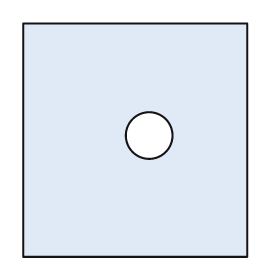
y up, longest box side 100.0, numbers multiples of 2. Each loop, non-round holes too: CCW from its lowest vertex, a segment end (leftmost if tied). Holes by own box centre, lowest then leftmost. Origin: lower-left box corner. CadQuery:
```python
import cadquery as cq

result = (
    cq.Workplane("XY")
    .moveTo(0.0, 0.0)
    .lineTo(96.0, 0.0)
    .lineTo(96.0, 100.0)
    .lineTo(0.0, 100.0)
    .close()
    .moveTo(54.0, 52.0)
    .circle(10.0)
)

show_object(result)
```